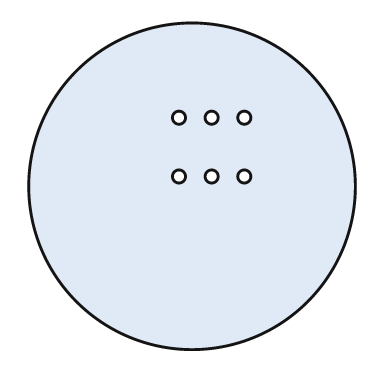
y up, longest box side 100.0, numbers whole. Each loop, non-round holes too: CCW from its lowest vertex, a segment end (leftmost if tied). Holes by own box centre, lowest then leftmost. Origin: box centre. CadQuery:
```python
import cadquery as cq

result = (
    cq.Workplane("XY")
    .moveTo(0.0, 0.0)
    .circle(50.0)
    .moveTo(-4.0, 3.0)
    .circle(2.0)
    .moveTo(6.0, 3.0)
    .circle(2.0)
    .moveTo(16.0, 3.0)
    .circle(2.0)
    .moveTo(-4.0, 21.0)
    .circle(2.0)
    .moveTo(6.0, 21.0)
    .circle(2.0)
    .moveTo(16.0, 21.0)
    .circle(2.0)
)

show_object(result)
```